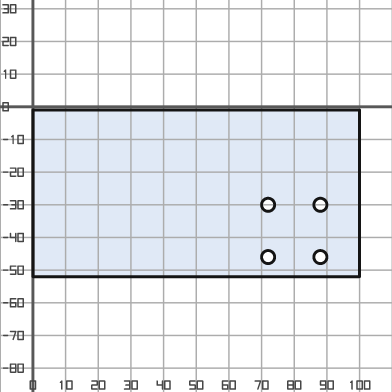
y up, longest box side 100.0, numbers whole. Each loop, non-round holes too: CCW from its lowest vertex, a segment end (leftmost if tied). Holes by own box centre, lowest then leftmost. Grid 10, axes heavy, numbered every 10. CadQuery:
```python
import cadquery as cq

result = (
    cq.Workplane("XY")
    .moveTo(0.0, -52.0)
    .lineTo(100.0, -52.0)
    .lineTo(100.0, -1.0)
    .lineTo(0.0, -1.0)
    .close()
    .moveTo(72.0, -46.0)
    .circle(2.0)
    .moveTo(88.0, -46.0)
    .circle(2.0)
    .moveTo(72.0, -30.0)
    .circle(2.0)
    .moveTo(88.0, -30.0)
    .circle(2.0)
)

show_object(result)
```